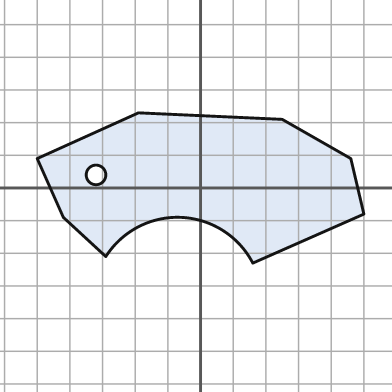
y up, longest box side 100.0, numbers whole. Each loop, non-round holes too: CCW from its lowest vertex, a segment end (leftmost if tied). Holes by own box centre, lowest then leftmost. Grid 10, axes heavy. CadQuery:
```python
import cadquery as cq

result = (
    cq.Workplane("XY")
    .moveTo(16.0, -23.0)
    .lineTo(50.0, -8.0)
    .lineTo(46.0, 9.0)
    .lineTo(25.0, 21.0)
    .lineTo(-19.0, 23.0)
    .lineTo(-50.0, 9.0)
    .lineTo(-42.0, -9.0)
    .lineTo(-29.0, -21.0)
    .threePointArc((-6.0, -9.0), (16.0, -23.0))
    .close()
    .moveTo(-32.0, 4.0)
    .circle(3.0)
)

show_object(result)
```